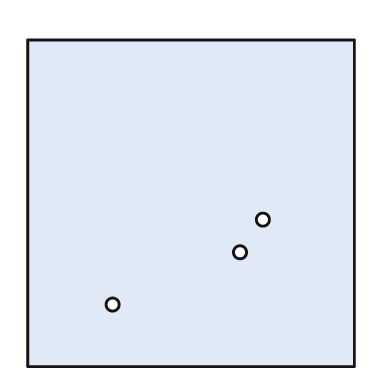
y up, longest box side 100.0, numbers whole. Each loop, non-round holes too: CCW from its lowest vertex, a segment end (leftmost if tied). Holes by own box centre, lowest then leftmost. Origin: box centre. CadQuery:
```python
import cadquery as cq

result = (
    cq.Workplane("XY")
    .moveTo(-50.0, -50.0)
    .lineTo(50.0, -50.0)
    .lineTo(50.0, 50.0)
    .lineTo(-50.0, 50.0)
    .close()
    .moveTo(-24.0, -31.0)
    .circle(2.0)
    .moveTo(15.0, -15.0)
    .circle(2.0)
    .moveTo(22.0, -5.0)
    .circle(2.0)
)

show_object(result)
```